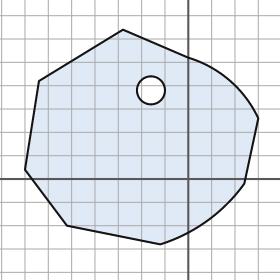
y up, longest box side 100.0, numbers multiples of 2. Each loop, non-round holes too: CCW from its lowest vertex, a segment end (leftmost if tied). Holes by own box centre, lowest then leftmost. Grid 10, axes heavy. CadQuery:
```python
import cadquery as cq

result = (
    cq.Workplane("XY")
    .moveTo(-12.0, -28.0)
    .threePointArc((8.0, -18.0), (24.0, -2.0))
    .lineTo(30.0, 26.0)
    .threePointArc((18.0, 42.0), (0.0, 52.0))
    .lineTo(-28.0, 64.0)
    .lineTo(-64.0, 42.0)
    .lineTo(-70.0, 4.0)
    .lineTo(-52.0, -20.0)
    .close()
    .moveTo(-16.0, 38.0)
    .circle(6.0)
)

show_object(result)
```